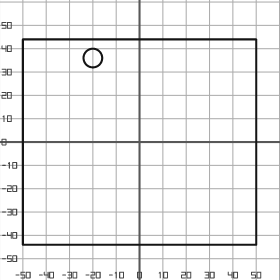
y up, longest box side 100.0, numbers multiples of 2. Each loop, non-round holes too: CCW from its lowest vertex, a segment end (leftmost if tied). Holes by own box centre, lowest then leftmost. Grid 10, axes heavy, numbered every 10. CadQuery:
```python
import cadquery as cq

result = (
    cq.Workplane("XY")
    .moveTo(-50.0, -44.0)
    .lineTo(50.0, -44.0)
    .lineTo(50.0, 44.0)
    .lineTo(-50.0, 44.0)
    .close()
    .moveTo(-20.0, 36.0)
    .circle(4.0)
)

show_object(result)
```